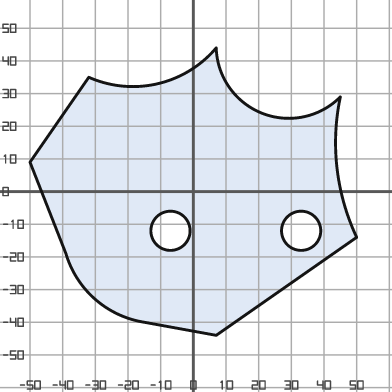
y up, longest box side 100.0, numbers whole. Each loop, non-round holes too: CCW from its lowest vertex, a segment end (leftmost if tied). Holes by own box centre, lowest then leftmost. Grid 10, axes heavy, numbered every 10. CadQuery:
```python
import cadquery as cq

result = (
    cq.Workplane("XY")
    .moveTo(7.0, -44.0)
    .lineTo(50.0, -14.0)
    .threePointArc((44.0, 7.0), (45.0, 29.0))
    .threePointArc((21.0, 24.0), (7.0, 44.0))
    .threePointArc((-11.0, 33.0), (-32.0, 35.0))
    .lineTo(-50.0, 9.0)
    .lineTo(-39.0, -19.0)
    .threePointArc((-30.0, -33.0), (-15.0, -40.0))
    .close()
    .moveTo(-7.0, -12.0)
    .circle(6.0)
    .moveTo(33.0, -12.0)
    .circle(6.0)
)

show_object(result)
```